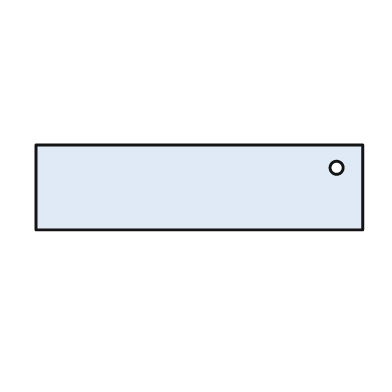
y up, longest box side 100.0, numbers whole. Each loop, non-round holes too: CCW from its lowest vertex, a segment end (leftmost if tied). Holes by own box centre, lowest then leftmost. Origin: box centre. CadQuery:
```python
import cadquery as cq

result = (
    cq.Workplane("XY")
    .moveTo(-50.0, -13.0)
    .lineTo(50.0, -13.0)
    .lineTo(50.0, 13.0)
    .lineTo(-50.0, 13.0)
    .close()
    .moveTo(42.0, 6.0)
    .circle(2.0)
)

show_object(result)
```